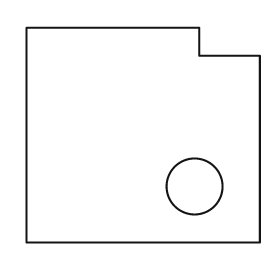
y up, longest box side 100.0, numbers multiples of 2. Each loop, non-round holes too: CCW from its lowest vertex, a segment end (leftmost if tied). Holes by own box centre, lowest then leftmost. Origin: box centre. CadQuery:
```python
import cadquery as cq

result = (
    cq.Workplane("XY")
    .moveTo(-50.0, -46.0)
    .lineTo(50.0, -46.0)
    .lineTo(50.0, 34.0)
    .lineTo(24.0, 34.0)
    .lineTo(24.0, 46.0)
    .lineTo(-50.0, 46.0)
    .close()
    .moveTo(22.0, -22.0)
    .circle(12.0)
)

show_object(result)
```